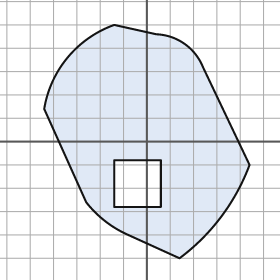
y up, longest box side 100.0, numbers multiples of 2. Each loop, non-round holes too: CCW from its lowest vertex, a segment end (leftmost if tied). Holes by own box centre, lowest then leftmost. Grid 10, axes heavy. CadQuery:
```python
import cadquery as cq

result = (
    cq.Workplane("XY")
    .moveTo(14.0, -50.0)
    .threePointArc((32.0, -32.0), (44.0, -10.0))
    .lineTo(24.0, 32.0)
    .threePointArc((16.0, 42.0), (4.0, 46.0))
    .lineTo(-14.0, 50.0)
    .threePointArc((-34.0, 36.0), (-44.0, 14.0))
    .lineTo(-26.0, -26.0)
    .threePointArc((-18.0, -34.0), (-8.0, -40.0))
    .close()
    .moveTo(-14.0, -28.0)
    .lineTo(6.0, -28.0)
    .lineTo(6.0, -8.0)
    .lineTo(-14.0, -8.0)
    .close()
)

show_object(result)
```